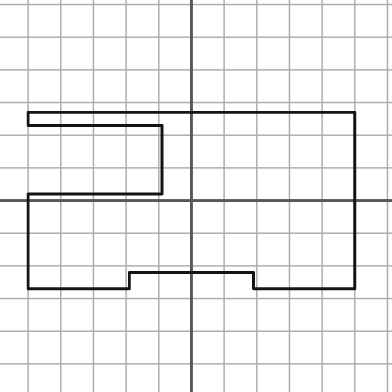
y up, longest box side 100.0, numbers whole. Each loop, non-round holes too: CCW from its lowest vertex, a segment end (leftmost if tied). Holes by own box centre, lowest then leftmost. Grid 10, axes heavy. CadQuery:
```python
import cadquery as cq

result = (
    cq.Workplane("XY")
    .moveTo(-50.0, -27.0)
    .lineTo(-19.0, -27.0)
    .lineTo(-19.0, -22.0)
    .lineTo(19.0, -22.0)
    .lineTo(19.0, -27.0)
    .lineTo(50.0, -27.0)
    .lineTo(50.0, 27.0)
    .lineTo(-50.0, 27.0)
    .lineTo(-50.0, 23.0)
    .lineTo(-9.0, 23.0)
    .lineTo(-9.0, 2.0)
    .lineTo(-50.0, 2.0)
    .close()
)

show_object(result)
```